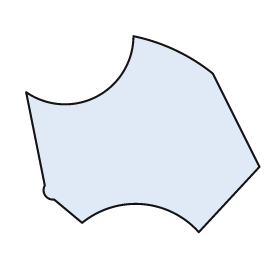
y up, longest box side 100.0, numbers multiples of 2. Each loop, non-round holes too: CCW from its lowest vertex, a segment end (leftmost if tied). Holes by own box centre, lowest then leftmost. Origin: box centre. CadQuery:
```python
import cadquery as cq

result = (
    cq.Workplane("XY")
    .moveTo(24.0, -42.0)
    .lineTo(50.0, -14.0)
    .lineTo(30.0, 26.0)
    .threePointArc((14.0, 36.0), (-4.0, 42.0))
    .threePointArc((-20.0, 16.0), (-50.0, 18.0))
    .lineTo(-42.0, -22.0)
    .threePointArc((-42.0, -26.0), (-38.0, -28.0))
    .lineTo(-26.0, -38.0)
    .threePointArc((0.0, -30.0), (24.0, -42.0))
    .close()
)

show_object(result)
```